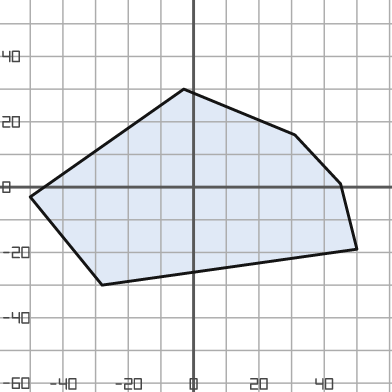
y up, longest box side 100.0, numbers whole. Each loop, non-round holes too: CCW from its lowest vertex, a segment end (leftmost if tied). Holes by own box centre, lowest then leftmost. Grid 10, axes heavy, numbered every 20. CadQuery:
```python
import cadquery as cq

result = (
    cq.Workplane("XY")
    .moveTo(-28.0, -30.0)
    .lineTo(50.0, -19.0)
    .lineTo(45.0, 1.0)
    .lineTo(31.0, 16.0)
    .lineTo(-3.0, 30.0)
    .lineTo(-50.0, -3.0)
    .close()
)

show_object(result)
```